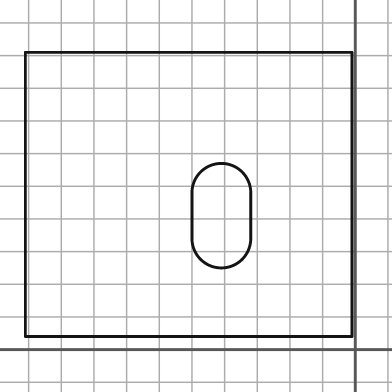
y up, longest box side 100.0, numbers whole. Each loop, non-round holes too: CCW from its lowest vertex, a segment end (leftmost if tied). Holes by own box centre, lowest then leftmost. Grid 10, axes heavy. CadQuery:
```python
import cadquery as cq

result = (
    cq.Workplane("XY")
    .moveTo(-101.0, 4.0)
    .lineTo(-1.0, 4.0)
    .lineTo(-1.0, 91.0)
    .lineTo(-101.0, 91.0)
    .close()
    .moveTo(-50.0, 34.0)
    .threePointArc((-41.0, 25.0), (-32.0, 34.0))
    .lineTo(-32.0, 48.0)
    .threePointArc((-41.0, 57.0), (-50.0, 48.0))
    .close()
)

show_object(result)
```